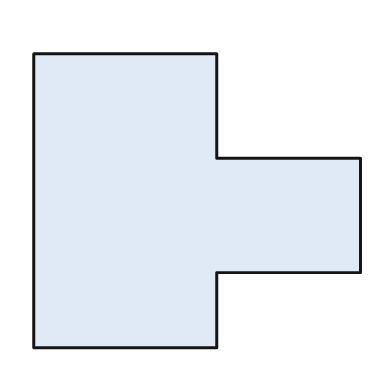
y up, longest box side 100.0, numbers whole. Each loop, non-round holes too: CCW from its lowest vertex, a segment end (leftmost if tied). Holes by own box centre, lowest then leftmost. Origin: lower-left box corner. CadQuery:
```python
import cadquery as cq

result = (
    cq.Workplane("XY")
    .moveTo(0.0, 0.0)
    .lineTo(56.0, 0.0)
    .lineTo(56.0, 23.0)
    .lineTo(100.0, 23.0)
    .lineTo(100.0, 58.0)
    .lineTo(56.0, 58.0)
    .lineTo(56.0, 90.0)
    .lineTo(0.0, 90.0)
    .close()
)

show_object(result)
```